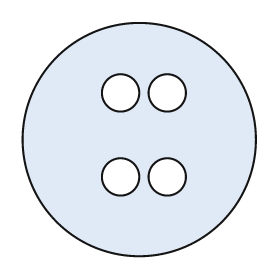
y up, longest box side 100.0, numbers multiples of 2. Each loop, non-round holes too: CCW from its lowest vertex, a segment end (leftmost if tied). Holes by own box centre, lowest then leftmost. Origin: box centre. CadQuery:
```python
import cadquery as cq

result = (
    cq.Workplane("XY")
    .moveTo(0.0, 0.0)
    .circle(50.0)
    .moveTo(-8.0, -16.0)
    .circle(8.0)
    .moveTo(12.0, -16.0)
    .circle(8.0)
    .moveTo(-8.0, 20.0)
    .circle(8.0)
    .moveTo(12.0, 20.0)
    .circle(8.0)
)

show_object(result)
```